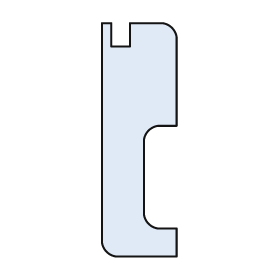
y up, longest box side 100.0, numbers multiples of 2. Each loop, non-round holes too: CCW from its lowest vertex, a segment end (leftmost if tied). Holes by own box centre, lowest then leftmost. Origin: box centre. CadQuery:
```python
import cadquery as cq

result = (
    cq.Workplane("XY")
    .moveTo(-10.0, -50.0)
    .lineTo(16.0, -50.0)
    .lineTo(16.0, -38.0)
    .lineTo(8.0, -38.0)
    .threePointArc((4.0, -36.0), (2.0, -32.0))
    .lineTo(2.0, 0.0)
    .threePointArc((4.0, 4.0), (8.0, 6.0))
    .lineTo(16.0, 6.0)
    .lineTo(16.0, 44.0)
    .threePointArc((14.0, 48.0), (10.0, 50.0))
    .lineTo(-4.0, 50.0)
    .lineTo(-4.0, 40.0)
    .lineTo(-12.0, 40.0)
    .lineTo(-12.0, 50.0)
    .lineTo(-16.0, 50.0)
    .lineTo(-16.0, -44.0)
    .threePointArc((-14.0, -48.0), (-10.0, -50.0))
    .close()
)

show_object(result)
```